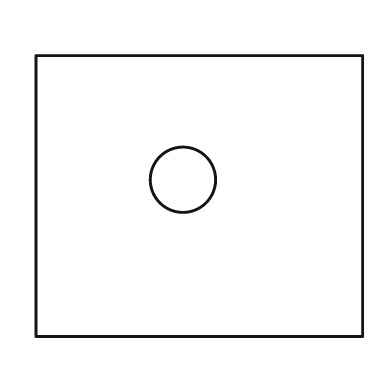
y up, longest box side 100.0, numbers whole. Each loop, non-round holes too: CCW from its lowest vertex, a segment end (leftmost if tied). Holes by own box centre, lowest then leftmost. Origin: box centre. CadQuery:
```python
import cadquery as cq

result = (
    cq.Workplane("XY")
    .moveTo(-50.0, -43.0)
    .lineTo(50.0, -43.0)
    .lineTo(50.0, 43.0)
    .lineTo(-50.0, 43.0)
    .close()
    .moveTo(-5.0, 5.0)
    .circle(10.0)
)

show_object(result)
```